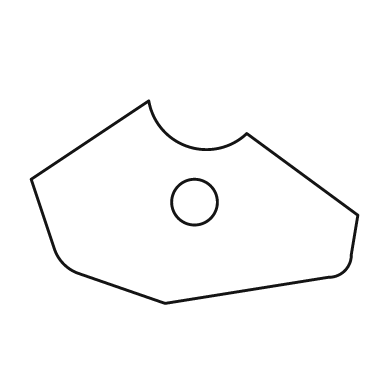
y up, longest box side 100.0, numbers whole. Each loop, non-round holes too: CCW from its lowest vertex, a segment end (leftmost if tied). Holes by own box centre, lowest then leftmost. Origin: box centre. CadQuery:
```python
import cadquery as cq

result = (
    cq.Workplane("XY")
    .moveTo(-9.0, -31.0)
    .lineTo(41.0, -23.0)
    .threePointArc((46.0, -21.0), (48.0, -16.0))
    .lineTo(50.0, -4.0)
    .lineTo(16.0, 21.0)
    .threePointArc((-2.0, 17.0), (-14.0, 31.0))
    .lineTo(-50.0, 7.0)
    .lineTo(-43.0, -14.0)
    .threePointArc((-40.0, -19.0), (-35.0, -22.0))
    .close()
    .moveTo(0.0, 0.0)
    .circle(7.0)
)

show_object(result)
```